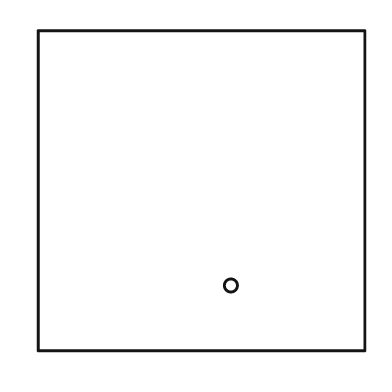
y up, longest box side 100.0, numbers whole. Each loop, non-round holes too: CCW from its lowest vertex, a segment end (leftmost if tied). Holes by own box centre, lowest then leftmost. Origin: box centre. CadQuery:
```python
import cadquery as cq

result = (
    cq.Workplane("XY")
    .moveTo(-50.0, -49.0)
    .lineTo(50.0, -49.0)
    .lineTo(50.0, 49.0)
    .lineTo(-50.0, 49.0)
    .close()
    .moveTo(9.0, -29.0)
    .circle(2.0)
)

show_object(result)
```